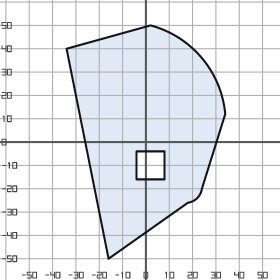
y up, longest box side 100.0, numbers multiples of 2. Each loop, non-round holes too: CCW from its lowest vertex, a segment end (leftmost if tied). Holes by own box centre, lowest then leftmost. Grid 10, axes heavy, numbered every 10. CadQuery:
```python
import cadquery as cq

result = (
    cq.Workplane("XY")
    .moveTo(-16.0, -50.0)
    .lineTo(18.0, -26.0)
    .threePointArc((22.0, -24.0), (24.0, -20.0))
    .lineTo(34.0, 12.0)
    .threePointArc((24.0, 36.0), (2.0, 50.0))
    .lineTo(-34.0, 40.0)
    .close()
    .moveTo(-4.0, -16.0)
    .lineTo(8.0, -16.0)
    .lineTo(8.0, -4.0)
    .lineTo(-4.0, -4.0)
    .close()
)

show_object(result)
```